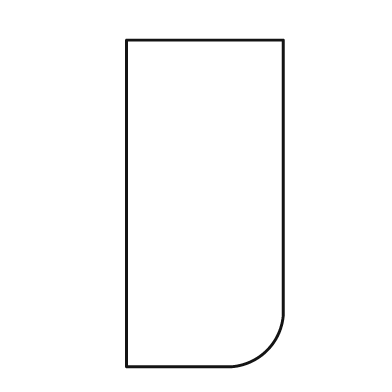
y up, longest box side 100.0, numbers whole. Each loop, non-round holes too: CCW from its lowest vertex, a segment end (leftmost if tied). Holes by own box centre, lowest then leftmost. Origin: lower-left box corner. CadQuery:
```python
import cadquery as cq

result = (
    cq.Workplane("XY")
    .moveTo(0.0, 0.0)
    .lineTo(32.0, 0.0)
    .threePointArc((43.0, 5.0), (48.0, 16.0))
    .lineTo(48.0, 100.0)
    .lineTo(0.0, 100.0)
    .close()
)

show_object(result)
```